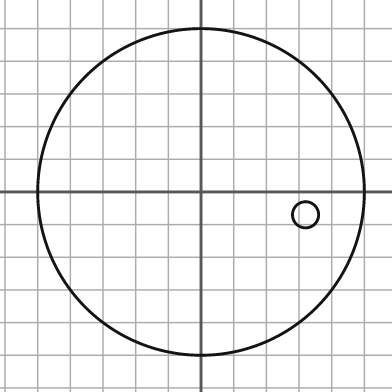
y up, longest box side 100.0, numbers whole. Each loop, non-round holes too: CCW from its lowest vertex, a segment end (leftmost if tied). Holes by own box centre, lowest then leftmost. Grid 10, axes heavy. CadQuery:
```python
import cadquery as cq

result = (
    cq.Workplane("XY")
    .moveTo(0.0, 0.0)
    .circle(50.0)
    .moveTo(32.0, -7.0)
    .circle(4.0)
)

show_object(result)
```